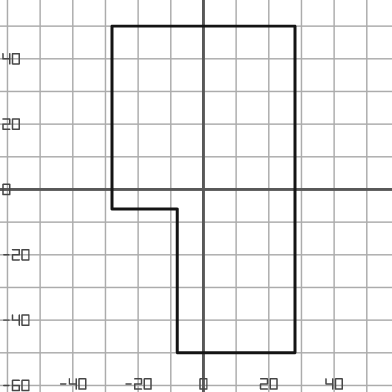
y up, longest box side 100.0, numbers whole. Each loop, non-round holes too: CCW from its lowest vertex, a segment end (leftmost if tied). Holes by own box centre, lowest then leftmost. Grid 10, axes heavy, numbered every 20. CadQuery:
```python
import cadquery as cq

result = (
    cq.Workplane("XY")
    .moveTo(-8.0, -50.0)
    .lineTo(28.0, -50.0)
    .lineTo(28.0, 50.0)
    .lineTo(-28.0, 50.0)
    .lineTo(-28.0, -6.0)
    .lineTo(-8.0, -6.0)
    .close()
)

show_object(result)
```